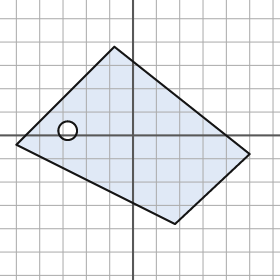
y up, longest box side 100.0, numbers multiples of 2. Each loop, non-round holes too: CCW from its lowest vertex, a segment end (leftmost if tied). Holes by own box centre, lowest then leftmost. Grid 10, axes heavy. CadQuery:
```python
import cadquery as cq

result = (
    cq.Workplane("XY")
    .moveTo(18.0, -38.0)
    .lineTo(50.0, -8.0)
    .lineTo(-8.0, 38.0)
    .lineTo(-50.0, -4.0)
    .close()
    .moveTo(-28.0, 2.0)
    .circle(4.0)
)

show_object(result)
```